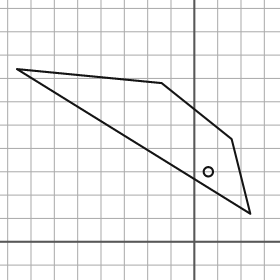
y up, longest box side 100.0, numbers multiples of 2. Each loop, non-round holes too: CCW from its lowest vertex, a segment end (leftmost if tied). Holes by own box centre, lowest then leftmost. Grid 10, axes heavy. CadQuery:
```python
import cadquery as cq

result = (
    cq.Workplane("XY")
    .moveTo(24.0, 12.0)
    .lineTo(16.0, 44.0)
    .lineTo(-14.0, 68.0)
    .lineTo(-76.0, 74.0)
    .close()
    .moveTo(6.0, 30.0)
    .circle(2.0)
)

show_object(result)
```